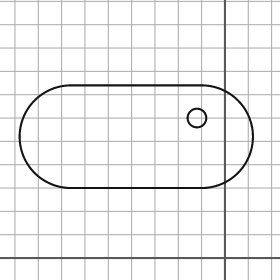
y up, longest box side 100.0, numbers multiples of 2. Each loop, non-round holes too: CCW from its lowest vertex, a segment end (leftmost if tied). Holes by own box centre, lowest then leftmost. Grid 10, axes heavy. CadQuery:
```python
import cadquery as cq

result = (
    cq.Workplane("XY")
    .moveTo(-66.0, 30.0)
    .lineTo(-10.0, 30.0)
    .threePointArc((12.0, 52.0), (-10.0, 74.0))
    .lineTo(-66.0, 74.0)
    .threePointArc((-88.0, 52.0), (-66.0, 30.0))
    .close()
    .moveTo(-12.0, 60.0)
    .circle(4.0)
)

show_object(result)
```